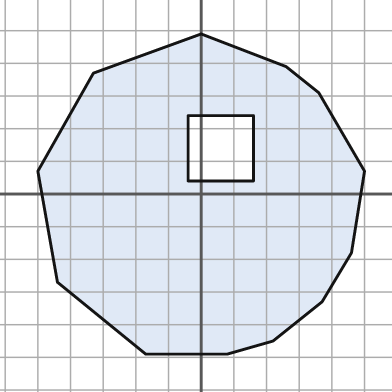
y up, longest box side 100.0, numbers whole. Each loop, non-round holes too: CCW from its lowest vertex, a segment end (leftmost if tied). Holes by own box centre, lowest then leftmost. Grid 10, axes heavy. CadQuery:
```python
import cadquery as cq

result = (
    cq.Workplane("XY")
    .moveTo(-17.0, -49.0)
    .lineTo(8.0, -49.0)
    .lineTo(22.0, -45.0)
    .lineTo(37.0, -33.0)
    .lineTo(46.0, -18.0)
    .lineTo(50.0, 7.0)
    .lineTo(36.0, 31.0)
    .lineTo(26.0, 39.0)
    .lineTo(0.0, 49.0)
    .lineTo(-33.0, 37.0)
    .lineTo(-50.0, 7.0)
    .lineTo(-44.0, -27.0)
    .close()
    .moveTo(-4.0, 4.0)
    .lineTo(16.0, 4.0)
    .lineTo(16.0, 24.0)
    .lineTo(-4.0, 24.0)
    .close()
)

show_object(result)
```